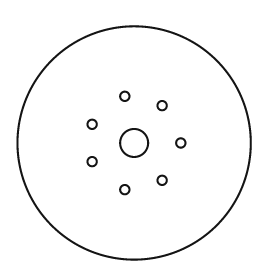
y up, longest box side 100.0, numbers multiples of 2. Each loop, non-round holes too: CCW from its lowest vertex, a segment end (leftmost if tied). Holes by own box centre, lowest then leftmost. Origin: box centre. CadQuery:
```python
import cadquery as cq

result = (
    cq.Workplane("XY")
    .moveTo(0.0, 0.0)
    .circle(50.0)
    .moveTo(-4.0, -20.0)
    .circle(2.0)
    .moveTo(12.0, -16.0)
    .circle(2.0)
    .moveTo(-18.0, -8.0)
    .circle(2.0)
    .moveTo(0.0, 0.0)
    .circle(6.0)
    .moveTo(20.0, 0.0)
    .circle(2.0)
    .moveTo(-18.0, 8.0)
    .circle(2.0)
    .moveTo(12.0, 16.0)
    .circle(2.0)
    .moveTo(-4.0, 20.0)
    .circle(2.0)
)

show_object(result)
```